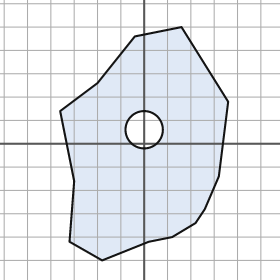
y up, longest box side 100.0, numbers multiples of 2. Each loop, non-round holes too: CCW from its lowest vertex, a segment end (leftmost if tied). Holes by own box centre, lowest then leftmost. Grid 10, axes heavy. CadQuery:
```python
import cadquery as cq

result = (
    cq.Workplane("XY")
    .moveTo(-18.0, -50.0)
    .lineTo(2.0, -42.0)
    .lineTo(12.0, -40.0)
    .lineTo(22.0, -34.0)
    .lineTo(26.0, -28.0)
    .lineTo(32.0, -14.0)
    .lineTo(36.0, 18.0)
    .lineTo(16.0, 50.0)
    .lineTo(-4.0, 46.0)
    .lineTo(-20.0, 26.0)
    .lineTo(-36.0, 14.0)
    .lineTo(-30.0, -16.0)
    .lineTo(-32.0, -42.0)
    .close()
    .moveTo(0.0, 6.0)
    .circle(8.0)
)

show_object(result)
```